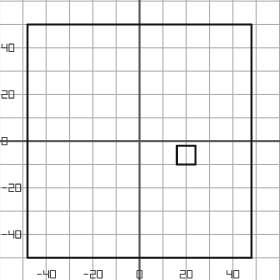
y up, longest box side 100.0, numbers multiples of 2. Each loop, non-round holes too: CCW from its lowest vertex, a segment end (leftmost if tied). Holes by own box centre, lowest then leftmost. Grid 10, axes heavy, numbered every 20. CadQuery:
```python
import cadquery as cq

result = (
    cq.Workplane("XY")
    .moveTo(-48.0, -50.0)
    .lineTo(48.0, -50.0)
    .lineTo(48.0, 50.0)
    .lineTo(-48.0, 50.0)
    .close()
    .moveTo(16.0, -10.0)
    .lineTo(24.0, -10.0)
    .lineTo(24.0, -2.0)
    .lineTo(16.0, -2.0)
    .close()
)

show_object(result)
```